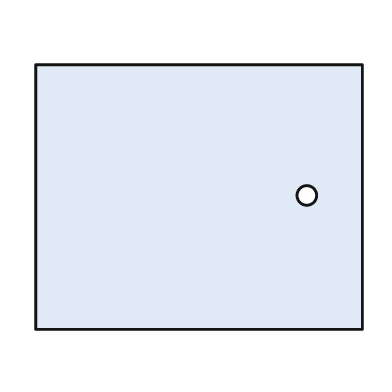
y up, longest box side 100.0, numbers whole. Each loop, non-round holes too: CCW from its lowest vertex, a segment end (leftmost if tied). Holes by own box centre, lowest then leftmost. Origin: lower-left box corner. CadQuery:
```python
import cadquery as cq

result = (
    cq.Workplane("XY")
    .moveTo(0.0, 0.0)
    .lineTo(100.0, 0.0)
    .lineTo(100.0, 81.0)
    .lineTo(0.0, 81.0)
    .close()
    .moveTo(83.0, 41.0)
    .circle(3.0)
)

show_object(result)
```